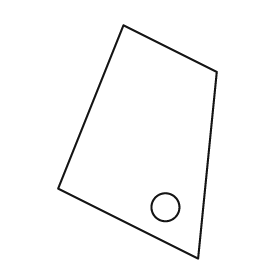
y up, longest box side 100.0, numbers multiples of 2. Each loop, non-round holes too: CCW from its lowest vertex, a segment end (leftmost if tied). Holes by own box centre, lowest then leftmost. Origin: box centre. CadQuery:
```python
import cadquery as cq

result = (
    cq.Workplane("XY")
    .moveTo(26.0, -50.0)
    .lineTo(34.0, 30.0)
    .lineTo(-6.0, 50.0)
    .lineTo(-34.0, -20.0)
    .close()
    .moveTo(12.0, -28.0)
    .circle(6.0)
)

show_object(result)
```